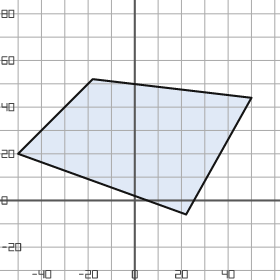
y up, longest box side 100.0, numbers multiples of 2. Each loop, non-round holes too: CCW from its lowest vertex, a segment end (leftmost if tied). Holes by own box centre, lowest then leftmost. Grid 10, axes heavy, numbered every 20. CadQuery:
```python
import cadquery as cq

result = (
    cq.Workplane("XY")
    .moveTo(22.0, -6.0)
    .lineTo(50.0, 44.0)
    .lineTo(-18.0, 52.0)
    .lineTo(-50.0, 20.0)
    .close()
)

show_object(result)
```